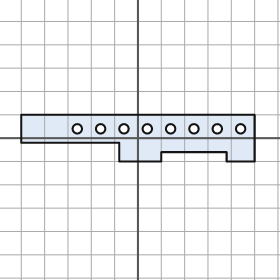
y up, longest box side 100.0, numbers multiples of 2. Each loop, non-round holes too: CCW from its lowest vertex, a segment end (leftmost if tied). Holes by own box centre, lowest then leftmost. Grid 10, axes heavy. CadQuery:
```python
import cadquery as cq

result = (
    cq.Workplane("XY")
    .moveTo(-8.0, -10.0)
    .lineTo(10.0, -10.0)
    .lineTo(10.0, -6.0)
    .lineTo(38.0, -6.0)
    .lineTo(38.0, -10.0)
    .lineTo(50.0, -10.0)
    .lineTo(50.0, 10.0)
    .lineTo(-50.0, 10.0)
    .lineTo(-50.0, -2.0)
    .lineTo(-8.0, -2.0)
    .close()
    .moveTo(-26.0, 4.0)
    .circle(2.0)
    .moveTo(-16.0, 4.0)
    .circle(2.0)
    .moveTo(-6.0, 4.0)
    .circle(2.0)
    .moveTo(4.0, 4.0)
    .circle(2.0)
    .moveTo(14.0, 4.0)
    .circle(2.0)
    .moveTo(24.0, 4.0)
    .circle(2.0)
    .moveTo(34.0, 4.0)
    .circle(2.0)
    .moveTo(44.0, 4.0)
    .circle(2.0)
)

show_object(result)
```